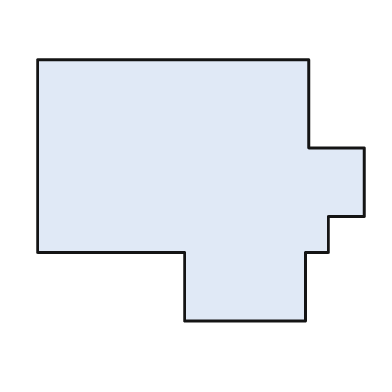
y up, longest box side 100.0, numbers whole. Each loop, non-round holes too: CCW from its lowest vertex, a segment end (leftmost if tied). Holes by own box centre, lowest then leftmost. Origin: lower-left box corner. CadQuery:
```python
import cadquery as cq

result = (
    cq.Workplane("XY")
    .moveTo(45.0, 0.0)
    .lineTo(82.0, 0.0)
    .lineTo(82.0, 21.0)
    .lineTo(89.0, 21.0)
    .lineTo(89.0, 32.0)
    .lineTo(100.0, 32.0)
    .lineTo(100.0, 53.0)
    .lineTo(83.0, 53.0)
    .lineTo(83.0, 80.0)
    .lineTo(0.0, 80.0)
    .lineTo(0.0, 21.0)
    .lineTo(45.0, 21.0)
    .close()
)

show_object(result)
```